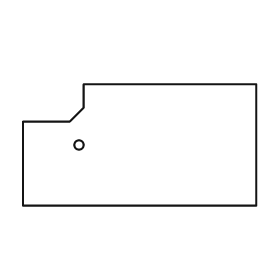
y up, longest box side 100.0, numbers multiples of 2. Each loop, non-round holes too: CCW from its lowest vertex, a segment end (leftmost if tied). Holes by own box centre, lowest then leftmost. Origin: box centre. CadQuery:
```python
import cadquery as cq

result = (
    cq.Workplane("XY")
    .moveTo(-50.0, -26.0)
    .lineTo(50.0, -26.0)
    .lineTo(50.0, 26.0)
    .lineTo(-24.0, 26.0)
    .lineTo(-24.0, 16.0)
    .lineTo(-30.0, 10.0)
    .lineTo(-50.0, 10.0)
    .close()
    .moveTo(-26.0, 0.0)
    .circle(2.0)
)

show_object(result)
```